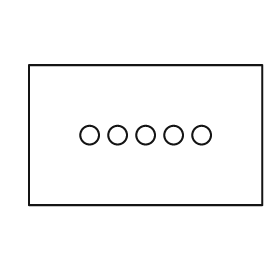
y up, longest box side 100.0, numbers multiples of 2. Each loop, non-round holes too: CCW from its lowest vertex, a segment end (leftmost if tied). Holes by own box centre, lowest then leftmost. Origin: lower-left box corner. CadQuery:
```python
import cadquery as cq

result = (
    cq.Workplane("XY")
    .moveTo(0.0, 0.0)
    .lineTo(100.0, 0.0)
    .lineTo(100.0, 60.0)
    .lineTo(0.0, 60.0)
    .close()
    .moveTo(26.0, 30.0)
    .circle(4.0)
    .moveTo(38.0, 30.0)
    .circle(4.0)
    .moveTo(50.0, 30.0)
    .circle(4.0)
    .moveTo(62.0, 30.0)
    .circle(4.0)
    .moveTo(74.0, 30.0)
    .circle(4.0)
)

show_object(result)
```